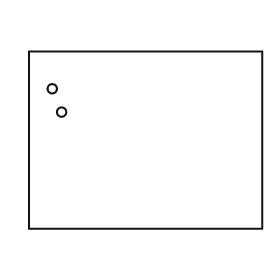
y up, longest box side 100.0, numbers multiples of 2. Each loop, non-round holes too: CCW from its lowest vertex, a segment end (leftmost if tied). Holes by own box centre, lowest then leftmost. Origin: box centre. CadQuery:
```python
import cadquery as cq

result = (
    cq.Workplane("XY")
    .moveTo(-50.0, -38.0)
    .lineTo(50.0, -38.0)
    .lineTo(50.0, 38.0)
    .lineTo(-50.0, 38.0)
    .close()
    .moveTo(-36.0, 12.0)
    .circle(2.0)
    .moveTo(-40.0, 22.0)
    .circle(2.0)
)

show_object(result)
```